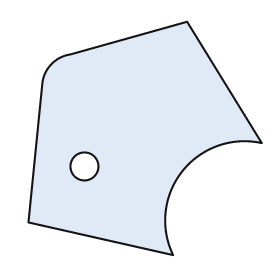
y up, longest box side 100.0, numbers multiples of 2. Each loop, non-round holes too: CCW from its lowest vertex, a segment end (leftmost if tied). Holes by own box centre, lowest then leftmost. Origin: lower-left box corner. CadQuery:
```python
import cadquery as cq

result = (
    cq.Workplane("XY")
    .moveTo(62.0, 0.0)
    .threePointArc((66.0, 36.0), (100.0, 48.0))
    .lineTo(68.0, 100.0)
    .lineTo(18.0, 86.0)
    .threePointArc((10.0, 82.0), (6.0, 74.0))
    .lineTo(0.0, 14.0)
    .close()
    .moveTo(24.0, 38.0)
    .circle(6.0)
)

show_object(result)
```